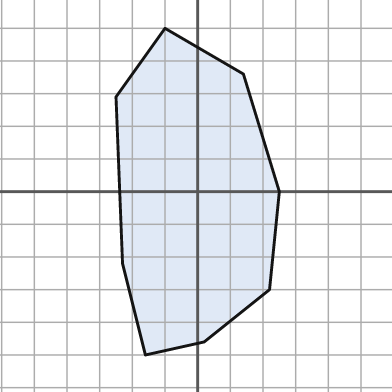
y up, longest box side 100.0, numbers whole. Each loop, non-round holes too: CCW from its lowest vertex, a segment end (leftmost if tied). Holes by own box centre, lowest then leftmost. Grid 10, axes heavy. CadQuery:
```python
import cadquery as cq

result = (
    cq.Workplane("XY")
    .moveTo(-16.0, -50.0)
    .lineTo(2.0, -46.0)
    .lineTo(22.0, -30.0)
    .lineTo(25.0, 0.0)
    .lineTo(14.0, 36.0)
    .lineTo(-10.0, 50.0)
    .lineTo(-25.0, 29.0)
    .lineTo(-23.0, -22.0)
    .close()
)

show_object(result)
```